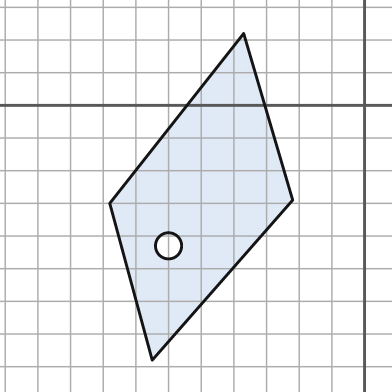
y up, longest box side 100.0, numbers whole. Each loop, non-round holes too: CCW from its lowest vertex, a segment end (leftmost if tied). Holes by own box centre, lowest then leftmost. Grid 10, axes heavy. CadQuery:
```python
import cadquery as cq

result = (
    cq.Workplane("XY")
    .moveTo(-65.0, -78.0)
    .lineTo(-22.0, -29.0)
    .lineTo(-37.0, 22.0)
    .lineTo(-78.0, -30.0)
    .close()
    .moveTo(-60.0, -43.0)
    .circle(4.0)
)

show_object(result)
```